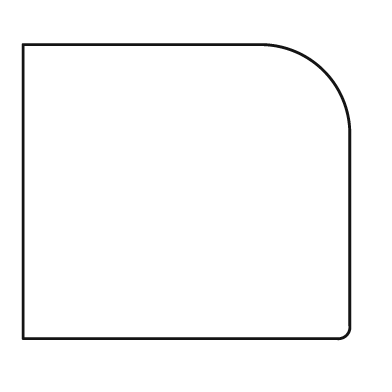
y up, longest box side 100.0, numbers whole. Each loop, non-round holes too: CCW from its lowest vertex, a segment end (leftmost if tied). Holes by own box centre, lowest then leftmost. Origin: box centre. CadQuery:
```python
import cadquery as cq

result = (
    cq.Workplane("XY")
    .moveTo(-50.0, -45.0)
    .lineTo(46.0, -45.0)
    .threePointArc((49.0, -44.0), (50.0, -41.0))
    .lineTo(50.0, 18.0)
    .threePointArc((42.0, 37.0), (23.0, 45.0))
    .lineTo(-50.0, 45.0)
    .close()
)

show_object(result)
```